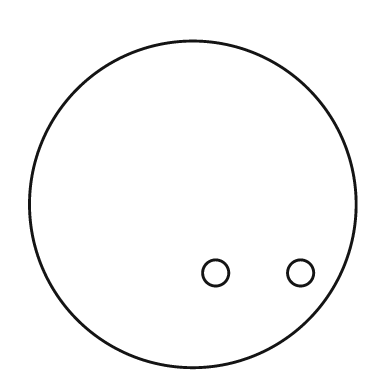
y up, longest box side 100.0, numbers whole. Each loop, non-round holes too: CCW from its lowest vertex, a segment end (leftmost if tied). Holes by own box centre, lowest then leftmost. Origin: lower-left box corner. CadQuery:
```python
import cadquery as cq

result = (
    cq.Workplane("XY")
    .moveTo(50.0, 50.0)
    .circle(50.0)
    .moveTo(57.0, 29.0)
    .circle(4.0)
    .moveTo(83.0, 29.0)
    .circle(4.0)
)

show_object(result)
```